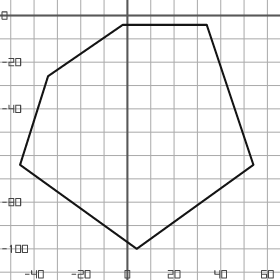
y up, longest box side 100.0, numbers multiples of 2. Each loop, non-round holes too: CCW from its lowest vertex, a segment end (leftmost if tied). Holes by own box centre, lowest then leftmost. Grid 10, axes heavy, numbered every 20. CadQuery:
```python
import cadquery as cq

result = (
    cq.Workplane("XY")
    .moveTo(4.0, -100.0)
    .lineTo(54.0, -64.0)
    .lineTo(34.0, -4.0)
    .lineTo(-2.0, -4.0)
    .lineTo(-34.0, -26.0)
    .lineTo(-46.0, -64.0)
    .close()
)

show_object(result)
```